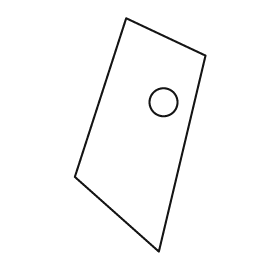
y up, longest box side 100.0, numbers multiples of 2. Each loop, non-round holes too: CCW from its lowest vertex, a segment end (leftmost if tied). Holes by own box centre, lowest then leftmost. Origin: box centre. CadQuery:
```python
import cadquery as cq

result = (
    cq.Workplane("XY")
    .moveTo(8.0, -50.0)
    .lineTo(28.0, 34.0)
    .lineTo(-6.0, 50.0)
    .lineTo(-28.0, -18.0)
    .close()
    .moveTo(10.0, 14.0)
    .circle(6.0)
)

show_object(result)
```